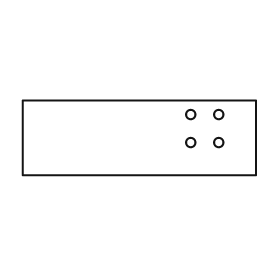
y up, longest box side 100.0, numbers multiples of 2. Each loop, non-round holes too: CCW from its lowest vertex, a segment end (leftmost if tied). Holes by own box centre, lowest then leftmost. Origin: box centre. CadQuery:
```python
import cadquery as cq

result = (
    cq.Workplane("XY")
    .moveTo(-50.0, -16.0)
    .lineTo(50.0, -16.0)
    .lineTo(50.0, 16.0)
    .lineTo(-50.0, 16.0)
    .close()
    .moveTo(22.0, -2.0)
    .circle(2.0)
    .moveTo(34.0, -2.0)
    .circle(2.0)
    .moveTo(22.0, 10.0)
    .circle(2.0)
    .moveTo(34.0, 10.0)
    .circle(2.0)
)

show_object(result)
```